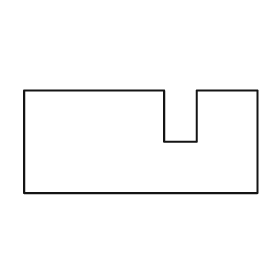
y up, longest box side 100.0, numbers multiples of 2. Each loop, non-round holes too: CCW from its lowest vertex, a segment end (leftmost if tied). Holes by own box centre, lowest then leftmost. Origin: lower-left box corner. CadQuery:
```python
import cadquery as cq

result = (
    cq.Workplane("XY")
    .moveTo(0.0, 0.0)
    .lineTo(100.0, 0.0)
    .lineTo(100.0, 44.0)
    .lineTo(74.0, 44.0)
    .lineTo(74.0, 22.0)
    .lineTo(60.0, 22.0)
    .lineTo(60.0, 44.0)
    .lineTo(0.0, 44.0)
    .close()
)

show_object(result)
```